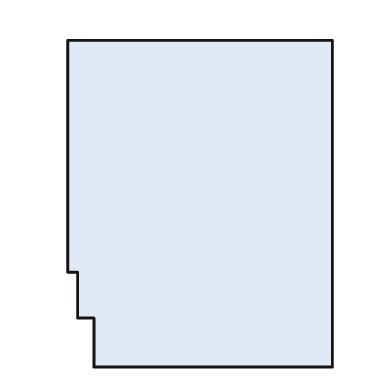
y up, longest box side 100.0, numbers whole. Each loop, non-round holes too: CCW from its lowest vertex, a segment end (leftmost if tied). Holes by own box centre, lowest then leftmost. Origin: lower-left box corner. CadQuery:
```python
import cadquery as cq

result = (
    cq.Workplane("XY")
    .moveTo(8.0, 0.0)
    .lineTo(81.0, 0.0)
    .lineTo(81.0, 100.0)
    .lineTo(0.0, 100.0)
    .lineTo(0.0, 29.0)
    .lineTo(3.0, 29.0)
    .lineTo(3.0, 15.0)
    .lineTo(8.0, 15.0)
    .close()
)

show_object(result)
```